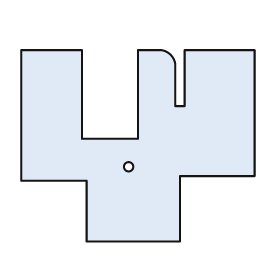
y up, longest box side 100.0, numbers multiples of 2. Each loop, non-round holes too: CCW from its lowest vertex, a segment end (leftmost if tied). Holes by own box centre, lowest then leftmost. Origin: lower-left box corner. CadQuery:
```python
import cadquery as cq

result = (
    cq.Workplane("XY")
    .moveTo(28.0, 0.0)
    .lineTo(68.0, 0.0)
    .lineTo(68.0, 28.0)
    .lineTo(100.0, 28.0)
    .lineTo(100.0, 82.0)
    .lineTo(70.0, 82.0)
    .lineTo(70.0, 58.0)
    .lineTo(66.0, 58.0)
    .lineTo(66.0, 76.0)
    .threePointArc((64.0, 80.0), (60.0, 82.0))
    .lineTo(50.0, 82.0)
    .lineTo(50.0, 44.0)
    .lineTo(26.0, 44.0)
    .lineTo(26.0, 82.0)
    .lineTo(0.0, 82.0)
    .lineTo(0.0, 26.0)
    .lineTo(28.0, 26.0)
    .close()
    .moveTo(46.0, 32.0)
    .circle(2.0)
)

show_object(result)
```